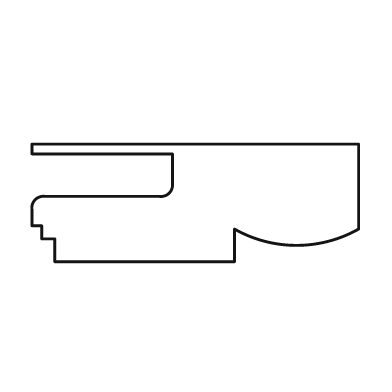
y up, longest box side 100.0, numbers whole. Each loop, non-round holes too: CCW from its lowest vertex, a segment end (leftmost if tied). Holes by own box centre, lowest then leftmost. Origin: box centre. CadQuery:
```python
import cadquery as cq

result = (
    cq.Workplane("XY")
    .moveTo(-43.0, -18.0)
    .lineTo(12.0, -18.0)
    .lineTo(12.0, -8.0)
    .threePointArc((31.0, -13.0), (50.0, -8.0))
    .lineTo(50.0, 18.0)
    .lineTo(-50.0, 18.0)
    .lineTo(-50.0, 15.0)
    .lineTo(-7.0, 15.0)
    .lineTo(-7.0, 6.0)
    .threePointArc((-8.0, 3.0), (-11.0, 2.0))
    .lineTo(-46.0, 2.0)
    .threePointArc((-49.0, 1.0), (-50.0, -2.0))
    .lineTo(-50.0, -7.0)
    .lineTo(-47.0, -7.0)
    .lineTo(-47.0, -11.0)
    .lineTo(-43.0, -11.0)
    .close()
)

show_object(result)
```